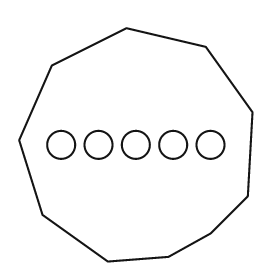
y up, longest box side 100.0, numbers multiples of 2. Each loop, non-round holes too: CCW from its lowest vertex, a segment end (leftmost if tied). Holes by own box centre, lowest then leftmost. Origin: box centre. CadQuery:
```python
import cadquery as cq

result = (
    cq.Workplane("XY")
    .moveTo(-12.0, -50.0)
    .lineTo(14.0, -48.0)
    .lineTo(32.0, -38.0)
    .lineTo(48.0, -22.0)
    .lineTo(50.0, 14.0)
    .lineTo(30.0, 42.0)
    .lineTo(-4.0, 50.0)
    .lineTo(-36.0, 34.0)
    .lineTo(-50.0, 2.0)
    .lineTo(-40.0, -30.0)
    .close()
    .moveTo(-32.0, 0.0)
    .circle(6.0)
    .moveTo(-16.0, 0.0)
    .circle(6.0)
    .moveTo(0.0, 0.0)
    .circle(6.0)
    .moveTo(16.0, 0.0)
    .circle(6.0)
    .moveTo(32.0, 0.0)
    .circle(6.0)
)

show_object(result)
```